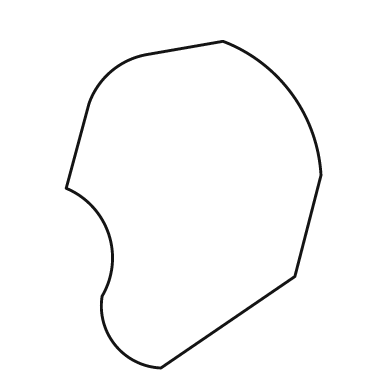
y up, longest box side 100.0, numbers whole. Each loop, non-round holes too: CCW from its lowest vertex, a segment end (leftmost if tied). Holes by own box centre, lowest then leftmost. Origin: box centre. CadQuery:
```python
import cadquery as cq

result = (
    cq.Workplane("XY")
    .moveTo(-10.0, -50.0)
    .lineTo(31.0, -22.0)
    .lineTo(39.0, 9.0)
    .threePointArc((30.0, 34.0), (9.0, 50.0))
    .lineTo(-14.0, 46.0)
    .threePointArc((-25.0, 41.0), (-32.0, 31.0))
    .lineTo(-39.0, 5.0)
    .threePointArc((-26.0, -9.0), (-28.0, -28.0))
    .threePointArc((-24.0, -43.0), (-10.0, -50.0))
    .close()
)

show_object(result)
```